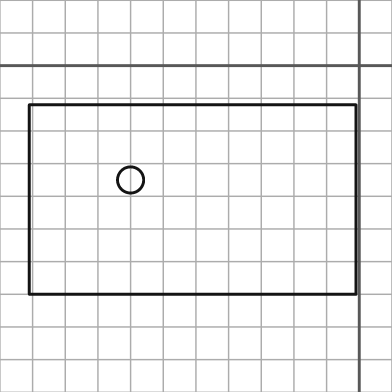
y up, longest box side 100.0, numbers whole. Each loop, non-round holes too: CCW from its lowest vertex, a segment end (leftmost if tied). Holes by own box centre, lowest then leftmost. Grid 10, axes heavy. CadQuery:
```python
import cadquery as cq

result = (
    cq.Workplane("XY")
    .moveTo(-101.0, -70.0)
    .lineTo(-1.0, -70.0)
    .lineTo(-1.0, -12.0)
    .lineTo(-101.0, -12.0)
    .close()
    .moveTo(-70.0, -35.0)
    .circle(4.0)
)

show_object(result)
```